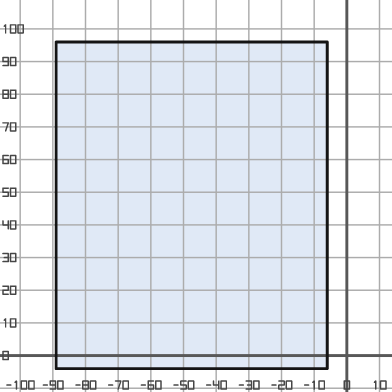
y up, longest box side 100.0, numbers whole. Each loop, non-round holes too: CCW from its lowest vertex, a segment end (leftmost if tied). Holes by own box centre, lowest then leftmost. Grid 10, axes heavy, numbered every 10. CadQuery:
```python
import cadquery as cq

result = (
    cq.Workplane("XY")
    .moveTo(-89.0, -4.0)
    .lineTo(-6.0, -4.0)
    .lineTo(-6.0, 96.0)
    .lineTo(-89.0, 96.0)
    .close()
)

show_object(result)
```